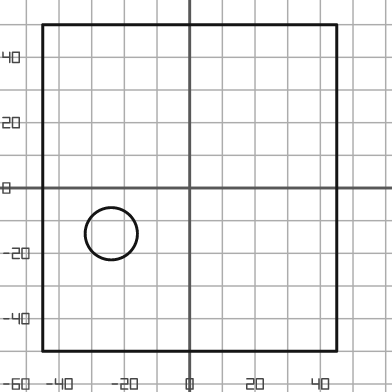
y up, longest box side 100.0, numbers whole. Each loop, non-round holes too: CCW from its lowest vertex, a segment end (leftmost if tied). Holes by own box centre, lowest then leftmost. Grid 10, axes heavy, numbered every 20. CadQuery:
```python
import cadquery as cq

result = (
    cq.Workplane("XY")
    .moveTo(-45.0, -50.0)
    .lineTo(45.0, -50.0)
    .lineTo(45.0, 50.0)
    .lineTo(-45.0, 50.0)
    .close()
    .moveTo(-24.0, -14.0)
    .circle(8.0)
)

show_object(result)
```